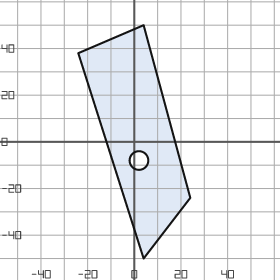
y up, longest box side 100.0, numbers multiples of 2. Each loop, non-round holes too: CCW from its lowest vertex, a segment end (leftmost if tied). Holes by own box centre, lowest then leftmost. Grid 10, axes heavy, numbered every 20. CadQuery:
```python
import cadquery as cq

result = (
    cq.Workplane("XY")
    .moveTo(4.0, -50.0)
    .lineTo(24.0, -24.0)
    .lineTo(4.0, 50.0)
    .lineTo(-24.0, 38.0)
    .close()
    .moveTo(2.0, -8.0)
    .circle(4.0)
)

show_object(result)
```